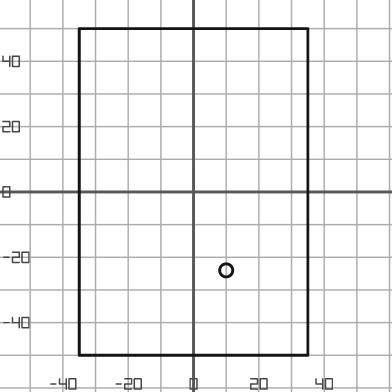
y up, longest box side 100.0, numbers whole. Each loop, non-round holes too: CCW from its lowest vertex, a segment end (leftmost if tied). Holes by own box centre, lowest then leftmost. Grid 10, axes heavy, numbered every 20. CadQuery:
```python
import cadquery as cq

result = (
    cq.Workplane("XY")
    .moveTo(-35.0, -50.0)
    .lineTo(35.0, -50.0)
    .lineTo(35.0, 50.0)
    .lineTo(-35.0, 50.0)
    .close()
    .moveTo(10.0, -24.0)
    .circle(2.0)
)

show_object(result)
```